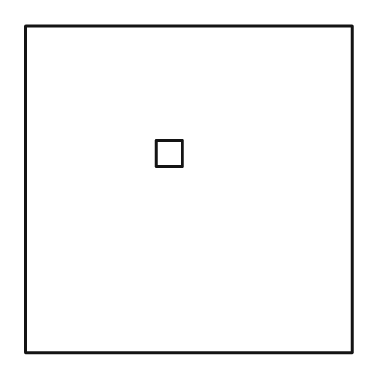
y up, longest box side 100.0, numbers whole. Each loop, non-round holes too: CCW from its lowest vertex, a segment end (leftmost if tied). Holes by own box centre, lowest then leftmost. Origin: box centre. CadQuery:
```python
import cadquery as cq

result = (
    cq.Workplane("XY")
    .moveTo(-50.0, -50.0)
    .lineTo(50.0, -50.0)
    .lineTo(50.0, 50.0)
    .lineTo(-50.0, 50.0)
    .close()
    .moveTo(-10.0, 7.0)
    .lineTo(-2.0, 7.0)
    .lineTo(-2.0, 15.0)
    .lineTo(-10.0, 15.0)
    .close()
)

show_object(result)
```